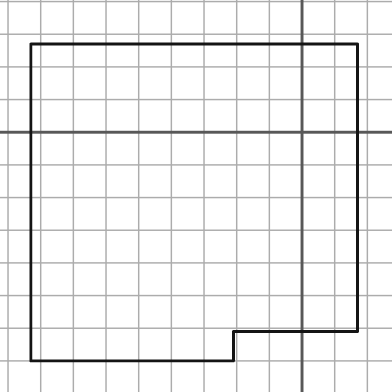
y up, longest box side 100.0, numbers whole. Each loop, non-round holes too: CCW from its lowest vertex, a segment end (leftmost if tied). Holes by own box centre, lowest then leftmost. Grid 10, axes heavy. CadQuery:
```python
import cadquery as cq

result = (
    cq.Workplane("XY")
    .moveTo(-83.0, -70.0)
    .lineTo(-21.0, -70.0)
    .lineTo(-21.0, -61.0)
    .lineTo(17.0, -61.0)
    .lineTo(17.0, 27.0)
    .lineTo(-83.0, 27.0)
    .close()
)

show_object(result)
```